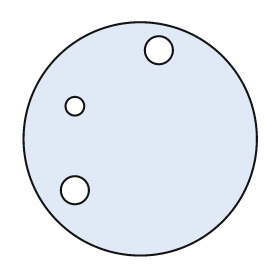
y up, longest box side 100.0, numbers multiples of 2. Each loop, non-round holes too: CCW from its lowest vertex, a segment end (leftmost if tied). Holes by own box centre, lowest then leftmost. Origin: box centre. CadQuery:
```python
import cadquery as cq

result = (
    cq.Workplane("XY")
    .moveTo(0.0, 0.0)
    .circle(50.0)
    .moveTo(-28.0, -22.0)
    .circle(6.0)
    .moveTo(-28.0, 14.0)
    .circle(4.0)
    .moveTo(8.0, 38.0)
    .circle(6.0)
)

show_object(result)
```